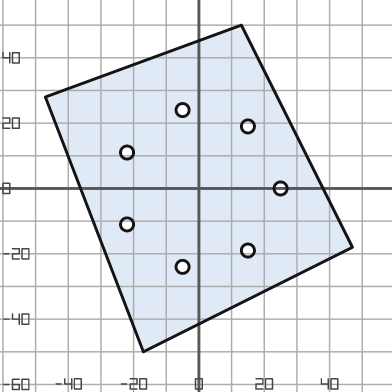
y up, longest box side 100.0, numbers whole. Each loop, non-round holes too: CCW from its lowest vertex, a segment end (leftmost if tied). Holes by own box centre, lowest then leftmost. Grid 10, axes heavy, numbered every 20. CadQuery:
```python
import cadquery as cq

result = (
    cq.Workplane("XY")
    .moveTo(-17.0, -50.0)
    .lineTo(47.0, -18.0)
    .lineTo(13.0, 50.0)
    .lineTo(-47.0, 28.0)
    .close()
    .moveTo(-5.0, -24.0)
    .circle(2.0)
    .moveTo(15.0, -19.0)
    .circle(2.0)
    .moveTo(-22.0, -11.0)
    .circle(2.0)
    .moveTo(25.0, 0.0)
    .circle(2.0)
    .moveTo(-22.0, 11.0)
    .circle(2.0)
    .moveTo(15.0, 19.0)
    .circle(2.0)
    .moveTo(-5.0, 24.0)
    .circle(2.0)
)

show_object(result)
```